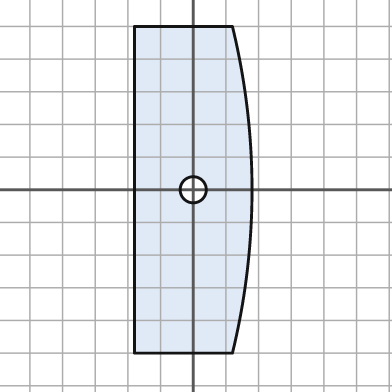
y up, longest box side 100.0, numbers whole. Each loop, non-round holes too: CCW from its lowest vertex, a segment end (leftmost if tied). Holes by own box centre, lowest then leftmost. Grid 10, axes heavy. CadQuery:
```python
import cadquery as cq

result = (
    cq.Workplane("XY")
    .moveTo(-18.0, -50.0)
    .lineTo(12.0, -50.0)
    .threePointArc((18.0, 0.0), (12.0, 50.0))
    .lineTo(-18.0, 50.0)
    .close()
    .moveTo(0.0, 0.0)
    .circle(4.0)
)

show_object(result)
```